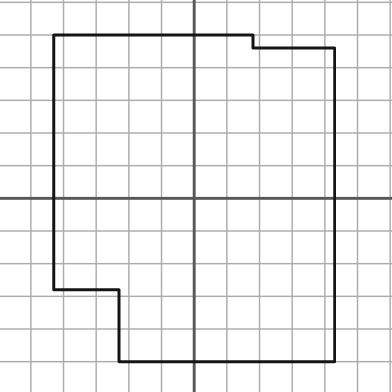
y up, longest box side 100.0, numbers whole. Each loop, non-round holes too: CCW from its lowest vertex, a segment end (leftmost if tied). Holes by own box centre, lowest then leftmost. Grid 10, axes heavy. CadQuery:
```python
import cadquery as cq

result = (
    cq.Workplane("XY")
    .moveTo(-23.0, -50.0)
    .lineTo(43.0, -50.0)
    .lineTo(43.0, 46.0)
    .lineTo(18.0, 46.0)
    .lineTo(18.0, 50.0)
    .lineTo(-43.0, 50.0)
    .lineTo(-43.0, -28.0)
    .lineTo(-23.0, -28.0)
    .close()
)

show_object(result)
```